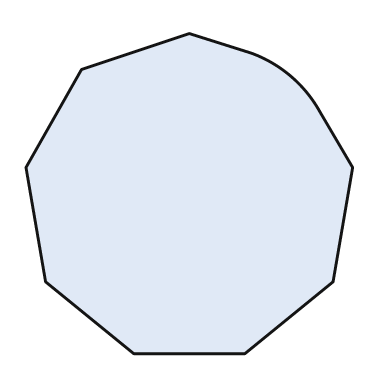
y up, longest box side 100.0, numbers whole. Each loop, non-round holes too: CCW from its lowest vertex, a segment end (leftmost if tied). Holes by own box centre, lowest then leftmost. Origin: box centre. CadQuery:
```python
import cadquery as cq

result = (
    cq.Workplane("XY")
    .moveTo(-17.0, -49.0)
    .lineTo(17.0, -49.0)
    .lineTo(44.0, -27.0)
    .lineTo(50.0, 8.0)
    .lineTo(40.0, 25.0)
    .threePointArc((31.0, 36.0), (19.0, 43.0))
    .lineTo(0.0, 49.0)
    .lineTo(-33.0, 38.0)
    .lineTo(-50.0, 8.0)
    .lineTo(-44.0, -27.0)
    .close()
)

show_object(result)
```